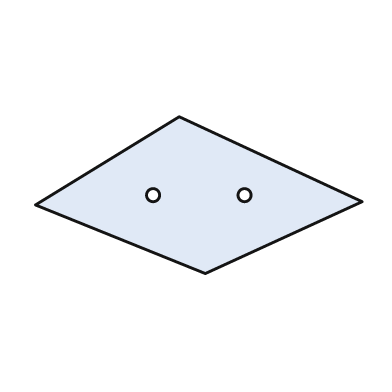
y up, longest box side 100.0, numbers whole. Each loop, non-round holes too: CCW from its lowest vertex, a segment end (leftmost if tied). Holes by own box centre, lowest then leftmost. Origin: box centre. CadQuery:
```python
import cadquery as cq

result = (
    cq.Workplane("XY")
    .moveTo(2.0, -24.0)
    .lineTo(50.0, -2.0)
    .lineTo(-6.0, 24.0)
    .lineTo(-50.0, -3.0)
    .close()
    .moveTo(-14.0, 0.0)
    .circle(2.0)
    .moveTo(14.0, 0.0)
    .circle(2.0)
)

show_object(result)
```